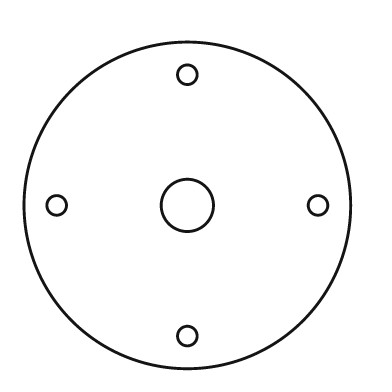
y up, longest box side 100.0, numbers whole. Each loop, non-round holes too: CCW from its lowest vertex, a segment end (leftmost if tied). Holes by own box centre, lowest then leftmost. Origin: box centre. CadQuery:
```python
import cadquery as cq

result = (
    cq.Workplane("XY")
    .moveTo(0.0, 0.0)
    .circle(50.0)
    .moveTo(0.0, -40.0)
    .circle(3.0)
    .moveTo(-40.0, 0.0)
    .circle(3.0)
    .moveTo(0.0, 0.0)
    .circle(8.0)
    .moveTo(40.0, 0.0)
    .circle(3.0)
    .moveTo(0.0, 40.0)
    .circle(3.0)
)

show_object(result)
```